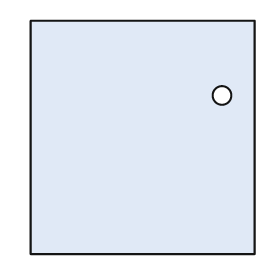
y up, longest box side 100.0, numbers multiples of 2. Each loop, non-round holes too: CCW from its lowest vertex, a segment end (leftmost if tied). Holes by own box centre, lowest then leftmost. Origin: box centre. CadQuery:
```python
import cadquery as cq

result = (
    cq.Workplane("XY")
    .moveTo(-48.0, -50.0)
    .lineTo(48.0, -50.0)
    .lineTo(48.0, 50.0)
    .lineTo(-48.0, 50.0)
    .close()
    .moveTo(34.0, 18.0)
    .circle(4.0)
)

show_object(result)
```